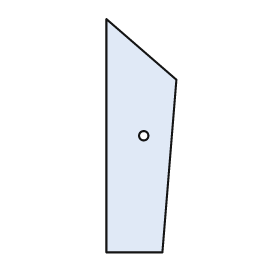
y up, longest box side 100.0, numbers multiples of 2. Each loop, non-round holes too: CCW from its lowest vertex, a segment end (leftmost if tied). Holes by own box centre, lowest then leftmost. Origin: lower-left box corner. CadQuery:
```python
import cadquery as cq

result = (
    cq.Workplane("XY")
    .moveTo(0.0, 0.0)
    .lineTo(24.0, 0.0)
    .lineTo(30.0, 74.0)
    .lineTo(0.0, 100.0)
    .close()
    .moveTo(16.0, 50.0)
    .circle(2.0)
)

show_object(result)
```